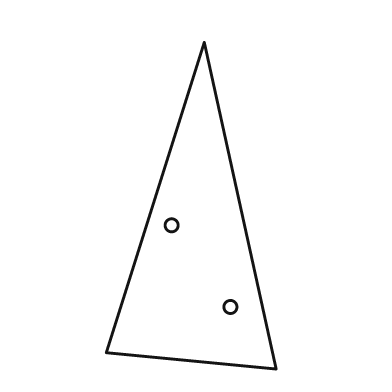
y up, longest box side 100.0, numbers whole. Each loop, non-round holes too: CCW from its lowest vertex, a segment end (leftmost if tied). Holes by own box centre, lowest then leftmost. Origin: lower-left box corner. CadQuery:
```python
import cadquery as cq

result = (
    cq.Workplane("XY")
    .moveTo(52.0, 0.0)
    .lineTo(30.0, 100.0)
    .lineTo(0.0, 5.0)
    .close()
    .moveTo(38.0, 19.0)
    .circle(2.0)
    .moveTo(20.0, 44.0)
    .circle(2.0)
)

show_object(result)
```